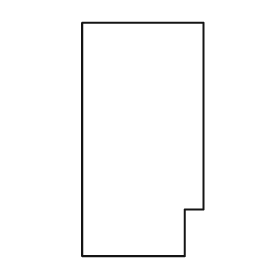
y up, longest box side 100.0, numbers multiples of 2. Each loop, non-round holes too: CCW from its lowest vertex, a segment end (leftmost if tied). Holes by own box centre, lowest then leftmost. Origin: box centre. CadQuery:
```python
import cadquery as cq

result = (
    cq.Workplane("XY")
    .moveTo(-26.0, -50.0)
    .lineTo(18.0, -50.0)
    .lineTo(18.0, -30.0)
    .lineTo(26.0, -30.0)
    .lineTo(26.0, 50.0)
    .lineTo(-26.0, 50.0)
    .close()
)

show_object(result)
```